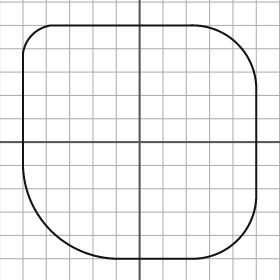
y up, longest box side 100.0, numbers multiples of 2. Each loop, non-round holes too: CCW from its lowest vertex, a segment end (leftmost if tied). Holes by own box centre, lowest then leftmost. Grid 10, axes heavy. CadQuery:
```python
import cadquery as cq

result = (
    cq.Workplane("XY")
    .moveTo(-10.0, -50.0)
    .lineTo(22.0, -50.0)
    .threePointArc((42.0, -42.0), (50.0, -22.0))
    .lineTo(50.0, 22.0)
    .threePointArc((42.0, 42.0), (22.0, 50.0))
    .lineTo(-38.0, 50.0)
    .threePointArc((-46.0, 46.0), (-50.0, 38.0))
    .lineTo(-50.0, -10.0)
    .threePointArc((-38.0, -38.0), (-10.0, -50.0))
    .close()
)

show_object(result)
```